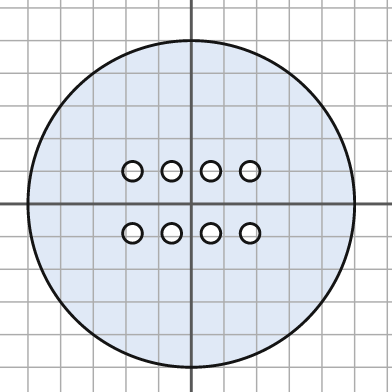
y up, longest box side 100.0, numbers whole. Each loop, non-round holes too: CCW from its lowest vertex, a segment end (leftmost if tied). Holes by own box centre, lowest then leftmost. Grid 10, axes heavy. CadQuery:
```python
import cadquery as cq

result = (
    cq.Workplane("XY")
    .moveTo(0.0, 0.0)
    .circle(50.0)
    .moveTo(-18.0, -9.0)
    .circle(3.0)
    .moveTo(-6.0, -9.0)
    .circle(3.0)
    .moveTo(6.0, -9.0)
    .circle(3.0)
    .moveTo(18.0, -9.0)
    .circle(3.0)
    .moveTo(-18.0, 10.0)
    .circle(3.0)
    .moveTo(-6.0, 10.0)
    .circle(3.0)
    .moveTo(6.0, 10.0)
    .circle(3.0)
    .moveTo(18.0, 10.0)
    .circle(3.0)
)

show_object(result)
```